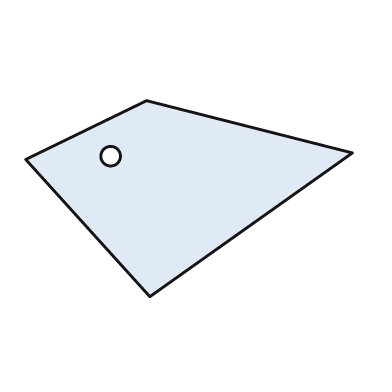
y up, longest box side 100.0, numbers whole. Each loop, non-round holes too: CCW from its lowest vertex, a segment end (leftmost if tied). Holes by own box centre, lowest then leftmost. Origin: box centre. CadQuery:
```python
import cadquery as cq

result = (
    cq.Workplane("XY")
    .moveTo(-12.0, -30.0)
    .lineTo(50.0, 14.0)
    .lineTo(-13.0, 30.0)
    .lineTo(-50.0, 12.0)
    .close()
    .moveTo(-24.0, 13.0)
    .circle(3.0)
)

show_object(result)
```